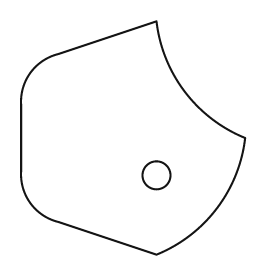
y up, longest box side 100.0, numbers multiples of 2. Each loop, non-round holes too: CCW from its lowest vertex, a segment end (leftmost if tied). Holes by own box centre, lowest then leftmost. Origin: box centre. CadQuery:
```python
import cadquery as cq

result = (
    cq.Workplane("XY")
    .moveTo(10.0, -50.0)
    .threePointArc((36.0, -30.0), (48.0, 0.0))
    .threePointArc((22.0, 20.0), (10.0, 50.0))
    .lineTo(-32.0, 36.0)
    .threePointArc((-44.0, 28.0), (-48.0, 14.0))
    .lineTo(-48.0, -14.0)
    .threePointArc((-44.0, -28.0), (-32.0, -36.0))
    .close()
    .moveTo(10.0, -16.0)
    .circle(6.0)
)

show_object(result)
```